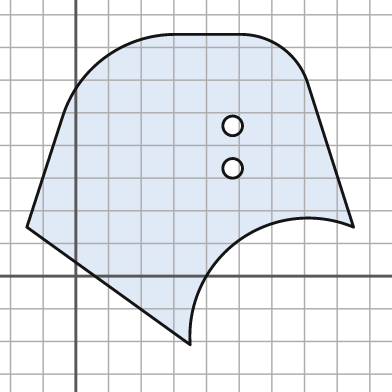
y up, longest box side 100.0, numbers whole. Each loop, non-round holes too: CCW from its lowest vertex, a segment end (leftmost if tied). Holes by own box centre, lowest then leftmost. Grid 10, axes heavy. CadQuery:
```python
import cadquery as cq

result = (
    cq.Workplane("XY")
    .moveTo(35.0, -21.0)
    .threePointArc((50.0, 11.0), (85.0, 15.0))
    .lineTo(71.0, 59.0)
    .threePointArc((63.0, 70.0), (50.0, 74.0))
    .lineTo(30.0, 74.0)
    .threePointArc((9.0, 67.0), (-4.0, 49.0))
    .lineTo(-15.0, 15.0)
    .close()
    .moveTo(48.0, 33.0)
    .circle(3.0)
    .moveTo(48.0, 46.0)
    .circle(3.0)
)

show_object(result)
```